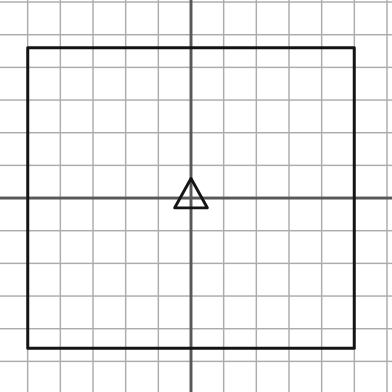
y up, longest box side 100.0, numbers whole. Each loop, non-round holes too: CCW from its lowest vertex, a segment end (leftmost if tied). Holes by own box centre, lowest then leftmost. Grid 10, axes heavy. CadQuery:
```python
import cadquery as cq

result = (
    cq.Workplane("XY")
    .moveTo(-50.0, -46.0)
    .lineTo(50.0, -46.0)
    .lineTo(50.0, 46.0)
    .lineTo(-50.0, 46.0)
    .close()
    .moveTo(-5.0, -3.0)
    .lineTo(5.0, -3.0)
    .lineTo(0.0, 6.0)
    .close()
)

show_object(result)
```